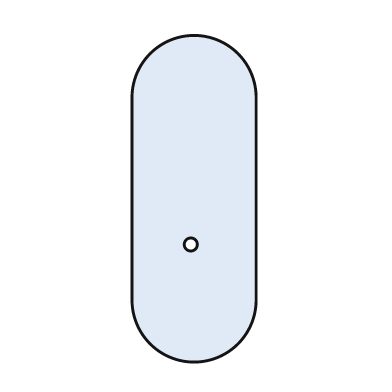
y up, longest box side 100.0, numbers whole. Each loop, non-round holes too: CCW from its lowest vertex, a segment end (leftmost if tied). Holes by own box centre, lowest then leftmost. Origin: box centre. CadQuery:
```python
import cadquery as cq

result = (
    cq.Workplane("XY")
    .moveTo(-19.0, -31.0)
    .threePointArc((0.0, -50.0), (19.0, -31.0))
    .lineTo(19.0, 31.0)
    .threePointArc((0.0, 50.0), (-19.0, 31.0))
    .close()
    .moveTo(-1.0, -14.0)
    .circle(2.0)
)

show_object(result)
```